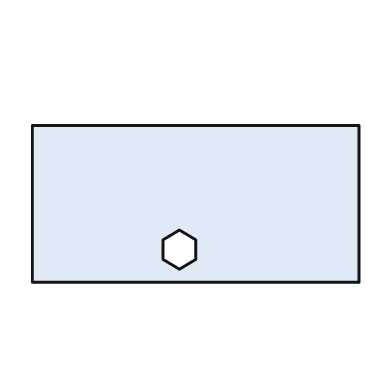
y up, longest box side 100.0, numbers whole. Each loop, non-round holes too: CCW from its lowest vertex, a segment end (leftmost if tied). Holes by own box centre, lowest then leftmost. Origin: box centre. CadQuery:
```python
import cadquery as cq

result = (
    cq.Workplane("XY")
    .moveTo(-50.0, -24.0)
    .lineTo(50.0, -24.0)
    .lineTo(50.0, 24.0)
    .lineTo(-50.0, 24.0)
    .close()
    .moveTo(-5.0, -20.0)
    .lineTo(0.0, -17.0)
    .lineTo(0.0, -11.0)
    .lineTo(-5.0, -8.0)
    .lineTo(-10.0, -11.0)
    .lineTo(-10.0, -17.0)
    .close()
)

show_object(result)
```